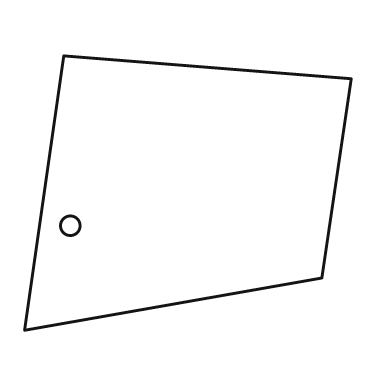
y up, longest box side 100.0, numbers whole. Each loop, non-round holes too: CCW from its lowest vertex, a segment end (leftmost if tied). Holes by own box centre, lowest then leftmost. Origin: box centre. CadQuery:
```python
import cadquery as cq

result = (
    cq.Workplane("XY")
    .moveTo(-50.0, -42.0)
    .lineTo(41.0, -26.0)
    .lineTo(50.0, 35.0)
    .lineTo(-38.0, 42.0)
    .close()
    .moveTo(-36.0, -10.0)
    .circle(3.0)
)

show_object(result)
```